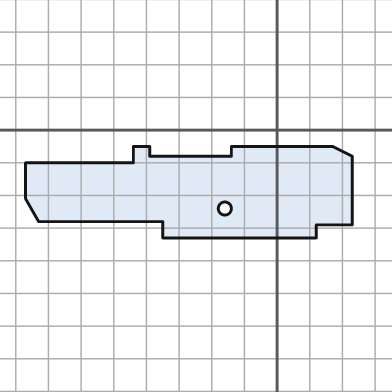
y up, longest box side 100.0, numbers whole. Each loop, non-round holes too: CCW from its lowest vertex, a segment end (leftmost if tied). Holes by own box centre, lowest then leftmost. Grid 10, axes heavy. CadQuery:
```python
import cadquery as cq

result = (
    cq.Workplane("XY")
    .moveTo(-35.0, -33.0)
    .lineTo(12.0, -33.0)
    .lineTo(12.0, -29.0)
    .lineTo(23.0, -29.0)
    .lineTo(23.0, -8.0)
    .lineTo(17.0, -5.0)
    .lineTo(-14.0, -5.0)
    .lineTo(-14.0, -8.0)
    .lineTo(-39.0, -8.0)
    .lineTo(-39.0, -5.0)
    .lineTo(-44.0, -5.0)
    .lineTo(-44.0, -10.0)
    .lineTo(-77.0, -10.0)
    .lineTo(-77.0, -21.0)
    .lineTo(-73.0, -28.0)
    .lineTo(-35.0, -28.0)
    .close()
    .moveTo(-16.0, -24.0)
    .circle(2.0)
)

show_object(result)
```